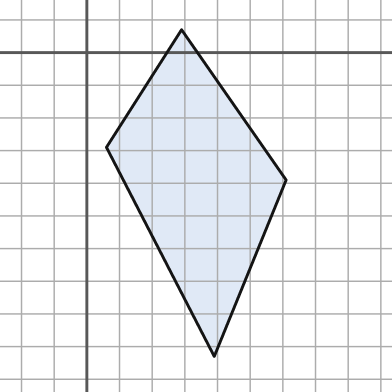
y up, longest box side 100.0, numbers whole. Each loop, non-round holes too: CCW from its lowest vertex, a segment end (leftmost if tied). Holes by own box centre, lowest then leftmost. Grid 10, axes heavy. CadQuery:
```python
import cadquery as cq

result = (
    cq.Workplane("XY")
    .moveTo(39.0, -93.0)
    .lineTo(61.0, -39.0)
    .lineTo(29.0, 7.0)
    .lineTo(6.0, -29.0)
    .close()
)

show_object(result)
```